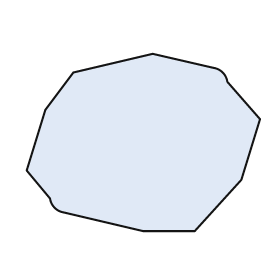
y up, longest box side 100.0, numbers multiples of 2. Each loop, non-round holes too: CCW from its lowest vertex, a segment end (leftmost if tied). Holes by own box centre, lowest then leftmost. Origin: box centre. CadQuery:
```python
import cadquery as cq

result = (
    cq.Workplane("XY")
    .moveTo(0.0, -38.0)
    .lineTo(22.0, -38.0)
    .lineTo(42.0, -16.0)
    .lineTo(50.0, 10.0)
    .lineTo(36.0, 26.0)
    .threePointArc((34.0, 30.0), (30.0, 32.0))
    .lineTo(4.0, 38.0)
    .lineTo(-30.0, 30.0)
    .lineTo(-42.0, 14.0)
    .lineTo(-50.0, -12.0)
    .lineTo(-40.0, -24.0)
    .threePointArc((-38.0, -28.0), (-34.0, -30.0))
    .close()
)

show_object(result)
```